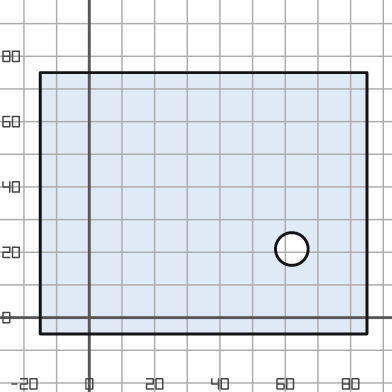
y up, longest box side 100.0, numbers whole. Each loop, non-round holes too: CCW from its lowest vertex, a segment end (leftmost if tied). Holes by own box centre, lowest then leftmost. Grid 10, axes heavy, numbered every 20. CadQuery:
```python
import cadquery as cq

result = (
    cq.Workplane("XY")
    .moveTo(-15.0, -5.0)
    .lineTo(85.0, -5.0)
    .lineTo(85.0, 75.0)
    .lineTo(-15.0, 75.0)
    .close()
    .moveTo(62.0, 21.0)
    .circle(5.0)
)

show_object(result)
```